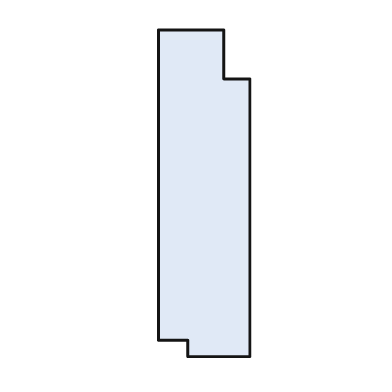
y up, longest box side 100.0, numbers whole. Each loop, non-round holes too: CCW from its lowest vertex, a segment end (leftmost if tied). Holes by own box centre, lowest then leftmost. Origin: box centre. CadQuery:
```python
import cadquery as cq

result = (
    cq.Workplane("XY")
    .moveTo(-5.0, -50.0)
    .lineTo(14.0, -50.0)
    .lineTo(14.0, 35.0)
    .lineTo(6.0, 35.0)
    .lineTo(6.0, 50.0)
    .lineTo(-14.0, 50.0)
    .lineTo(-14.0, -45.0)
    .lineTo(-5.0, -45.0)
    .close()
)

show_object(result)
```